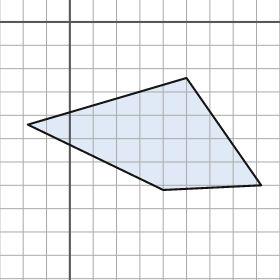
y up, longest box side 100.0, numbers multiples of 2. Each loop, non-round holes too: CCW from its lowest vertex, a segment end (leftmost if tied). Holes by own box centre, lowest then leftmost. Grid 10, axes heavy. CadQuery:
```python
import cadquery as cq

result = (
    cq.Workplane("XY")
    .moveTo(40.0, -72.0)
    .lineTo(82.0, -70.0)
    .lineTo(50.0, -24.0)
    .lineTo(-18.0, -44.0)
    .close()
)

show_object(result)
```